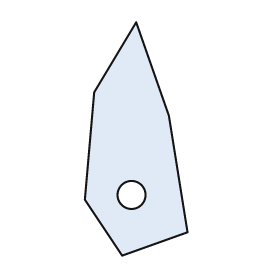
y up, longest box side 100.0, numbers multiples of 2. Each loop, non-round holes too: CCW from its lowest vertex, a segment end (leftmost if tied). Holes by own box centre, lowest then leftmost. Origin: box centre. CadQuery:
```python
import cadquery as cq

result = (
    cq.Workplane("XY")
    .moveTo(-6.0, -50.0)
    .lineTo(22.0, -40.0)
    .lineTo(14.0, 10.0)
    .lineTo(0.0, 50.0)
    .lineTo(-18.0, 20.0)
    .lineTo(-22.0, -26.0)
    .close()
    .moveTo(-2.0, -24.0)
    .circle(6.0)
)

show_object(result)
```